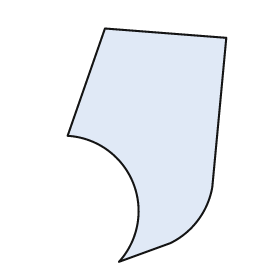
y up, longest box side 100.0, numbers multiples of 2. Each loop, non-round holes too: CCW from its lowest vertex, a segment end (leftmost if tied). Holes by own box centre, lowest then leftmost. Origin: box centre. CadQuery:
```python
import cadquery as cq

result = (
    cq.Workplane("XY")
    .moveTo(-12.0, -50.0)
    .lineTo(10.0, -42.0)
    .threePointArc((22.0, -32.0), (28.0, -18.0))
    .lineTo(34.0, 46.0)
    .lineTo(-18.0, 50.0)
    .lineTo(-34.0, 4.0)
    .threePointArc((-6.0, -16.0), (-12.0, -50.0))
    .close()
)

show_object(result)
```